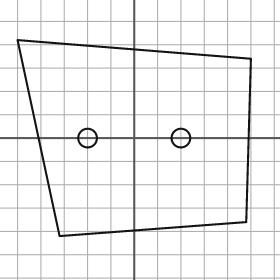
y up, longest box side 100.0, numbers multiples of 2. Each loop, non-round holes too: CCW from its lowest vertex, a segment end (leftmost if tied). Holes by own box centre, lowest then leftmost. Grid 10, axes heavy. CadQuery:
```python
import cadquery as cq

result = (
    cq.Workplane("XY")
    .moveTo(-32.0, -42.0)
    .lineTo(48.0, -36.0)
    .lineTo(50.0, 34.0)
    .lineTo(-50.0, 42.0)
    .close()
    .moveTo(-20.0, 0.0)
    .circle(4.0)
    .moveTo(20.0, 0.0)
    .circle(4.0)
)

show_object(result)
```